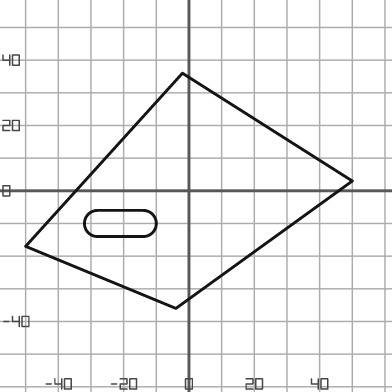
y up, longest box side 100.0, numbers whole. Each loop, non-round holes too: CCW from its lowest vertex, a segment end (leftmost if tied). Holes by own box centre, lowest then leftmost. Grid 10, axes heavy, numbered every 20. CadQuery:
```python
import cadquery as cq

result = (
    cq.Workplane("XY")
    .moveTo(-4.0, -36.0)
    .lineTo(50.0, 3.0)
    .lineTo(-2.0, 36.0)
    .lineTo(-50.0, -17.0)
    .close()
    .moveTo(-28.0, -14.0)
    .lineTo(-14.0, -14.0)
    .threePointArc((-10.0, -10.0), (-14.0, -6.0))
    .lineTo(-28.0, -6.0)
    .threePointArc((-32.0, -10.0), (-28.0, -14.0))
    .close()
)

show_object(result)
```